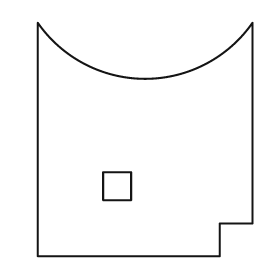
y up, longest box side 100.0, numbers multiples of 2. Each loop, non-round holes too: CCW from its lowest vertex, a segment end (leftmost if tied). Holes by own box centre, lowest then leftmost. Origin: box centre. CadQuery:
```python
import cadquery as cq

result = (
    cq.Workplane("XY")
    .moveTo(-46.0, -50.0)
    .lineTo(32.0, -50.0)
    .lineTo(32.0, -36.0)
    .lineTo(46.0, -36.0)
    .lineTo(46.0, 50.0)
    .threePointArc((0.0, 26.0), (-46.0, 50.0))
    .close()
    .moveTo(-18.0, -26.0)
    .lineTo(-6.0, -26.0)
    .lineTo(-6.0, -14.0)
    .lineTo(-18.0, -14.0)
    .close()
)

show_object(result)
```